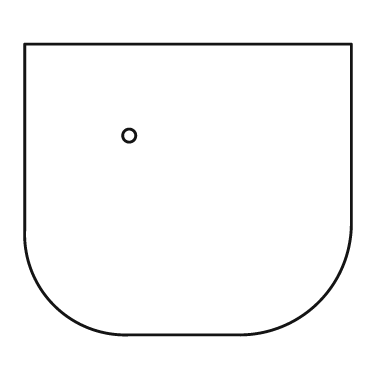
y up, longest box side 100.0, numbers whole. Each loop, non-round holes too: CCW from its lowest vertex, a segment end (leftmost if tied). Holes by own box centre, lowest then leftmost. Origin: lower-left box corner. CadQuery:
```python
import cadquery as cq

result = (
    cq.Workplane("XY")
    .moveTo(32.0, 0.0)
    .lineTo(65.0, 0.0)
    .threePointArc((90.0, 10.0), (100.0, 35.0))
    .lineTo(100.0, 89.0)
    .lineTo(0.0, 89.0)
    .lineTo(0.0, 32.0)
    .threePointArc((9.0, 9.0), (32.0, 0.0))
    .close()
    .moveTo(32.0, 61.0)
    .circle(2.0)
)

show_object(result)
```